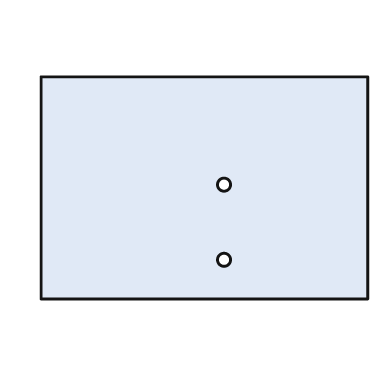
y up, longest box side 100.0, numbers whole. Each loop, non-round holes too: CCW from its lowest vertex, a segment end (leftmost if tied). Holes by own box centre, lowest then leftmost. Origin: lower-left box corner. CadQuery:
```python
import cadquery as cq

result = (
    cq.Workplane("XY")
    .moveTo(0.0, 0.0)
    .lineTo(100.0, 0.0)
    .lineTo(100.0, 68.0)
    .lineTo(0.0, 68.0)
    .close()
    .moveTo(56.0, 12.0)
    .circle(2.0)
    .moveTo(56.0, 35.0)
    .circle(2.0)
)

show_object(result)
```